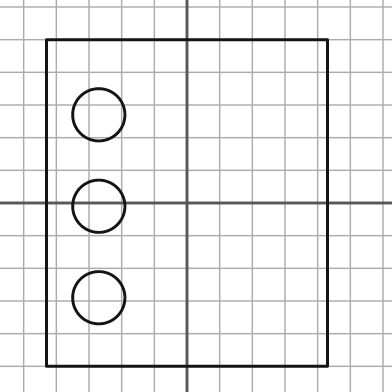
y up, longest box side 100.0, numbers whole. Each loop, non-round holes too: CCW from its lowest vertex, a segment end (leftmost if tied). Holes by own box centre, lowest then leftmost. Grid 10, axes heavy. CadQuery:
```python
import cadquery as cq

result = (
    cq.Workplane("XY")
    .moveTo(-43.0, -50.0)
    .lineTo(43.0, -50.0)
    .lineTo(43.0, 50.0)
    .lineTo(-43.0, 50.0)
    .close()
    .moveTo(-27.0, -29.0)
    .circle(8.0)
    .moveTo(-27.0, -1.0)
    .circle(8.0)
    .moveTo(-27.0, 27.0)
    .circle(8.0)
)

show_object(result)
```